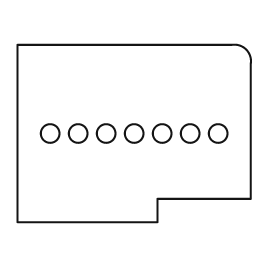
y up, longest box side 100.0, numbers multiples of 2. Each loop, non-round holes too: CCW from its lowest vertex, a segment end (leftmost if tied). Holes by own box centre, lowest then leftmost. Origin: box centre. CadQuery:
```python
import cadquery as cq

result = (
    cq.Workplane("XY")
    .moveTo(-50.0, -38.0)
    .lineTo(10.0, -38.0)
    .lineTo(10.0, -28.0)
    .lineTo(50.0, -28.0)
    .lineTo(50.0, 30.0)
    .threePointArc((48.0, 36.0), (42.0, 38.0))
    .lineTo(-50.0, 38.0)
    .close()
    .moveTo(-36.0, 0.0)
    .circle(4.0)
    .moveTo(-24.0, 0.0)
    .circle(4.0)
    .moveTo(-12.0, 0.0)
    .circle(4.0)
    .moveTo(0.0, 0.0)
    .circle(4.0)
    .moveTo(12.0, 0.0)
    .circle(4.0)
    .moveTo(24.0, 0.0)
    .circle(4.0)
    .moveTo(36.0, 0.0)
    .circle(4.0)
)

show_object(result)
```